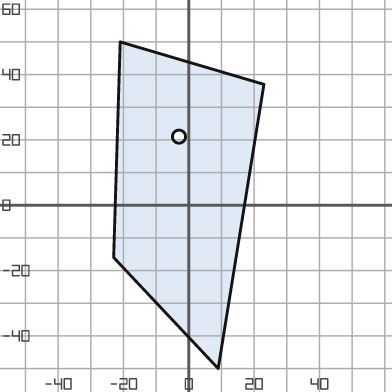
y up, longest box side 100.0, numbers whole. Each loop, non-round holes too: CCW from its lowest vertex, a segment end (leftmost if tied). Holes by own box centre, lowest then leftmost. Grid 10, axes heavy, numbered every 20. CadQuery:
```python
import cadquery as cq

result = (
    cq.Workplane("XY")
    .moveTo(9.0, -50.0)
    .lineTo(23.0, 37.0)
    .lineTo(-21.0, 50.0)
    .lineTo(-23.0, -16.0)
    .close()
    .moveTo(-3.0, 21.0)
    .circle(2.0)
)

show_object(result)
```